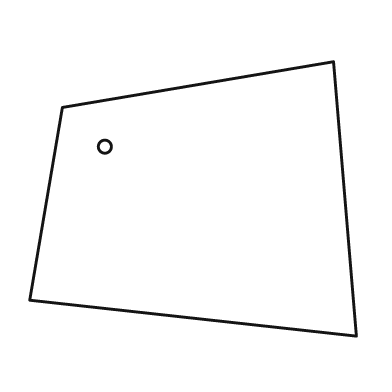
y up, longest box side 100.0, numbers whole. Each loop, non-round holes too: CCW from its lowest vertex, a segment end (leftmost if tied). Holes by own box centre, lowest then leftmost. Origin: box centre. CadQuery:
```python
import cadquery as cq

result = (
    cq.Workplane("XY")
    .moveTo(50.0, -42.0)
    .lineTo(43.0, 42.0)
    .lineTo(-40.0, 28.0)
    .lineTo(-50.0, -31.0)
    .close()
    .moveTo(-27.0, 16.0)
    .circle(2.0)
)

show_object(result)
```